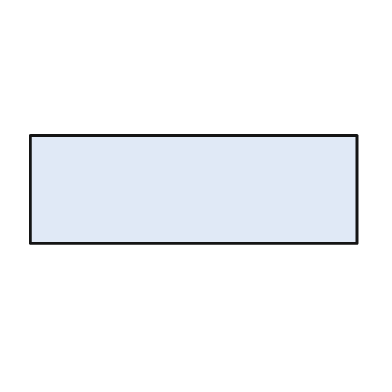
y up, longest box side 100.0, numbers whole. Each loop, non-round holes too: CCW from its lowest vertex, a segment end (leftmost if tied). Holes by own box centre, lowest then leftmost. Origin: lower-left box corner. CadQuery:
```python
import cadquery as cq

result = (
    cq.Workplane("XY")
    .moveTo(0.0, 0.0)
    .lineTo(100.0, 0.0)
    .lineTo(100.0, 33.0)
    .lineTo(0.0, 33.0)
    .close()
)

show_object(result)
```